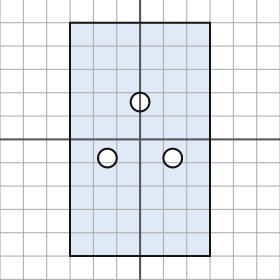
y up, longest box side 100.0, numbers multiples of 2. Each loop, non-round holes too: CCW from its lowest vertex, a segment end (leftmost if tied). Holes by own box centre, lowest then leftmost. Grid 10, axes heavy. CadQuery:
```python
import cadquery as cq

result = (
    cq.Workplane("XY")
    .moveTo(-30.0, -50.0)
    .lineTo(30.0, -50.0)
    .lineTo(30.0, 50.0)
    .lineTo(-30.0, 50.0)
    .close()
    .moveTo(-14.0, -8.0)
    .circle(4.0)
    .moveTo(14.0, -8.0)
    .circle(4.0)
    .moveTo(0.0, 16.0)
    .circle(4.0)
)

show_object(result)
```